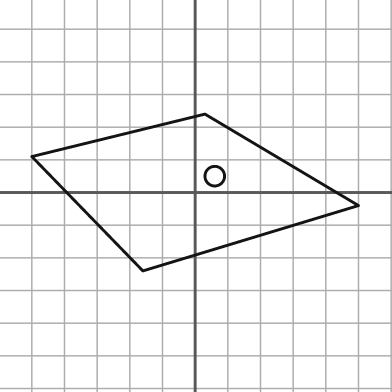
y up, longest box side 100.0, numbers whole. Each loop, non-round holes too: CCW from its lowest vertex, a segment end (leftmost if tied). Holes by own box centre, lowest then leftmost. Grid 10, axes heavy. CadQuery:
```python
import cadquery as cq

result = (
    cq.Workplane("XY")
    .moveTo(-16.0, -24.0)
    .lineTo(50.0, -4.0)
    .lineTo(3.0, 24.0)
    .lineTo(-50.0, 11.0)
    .close()
    .moveTo(6.0, 5.0)
    .circle(3.0)
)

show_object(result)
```